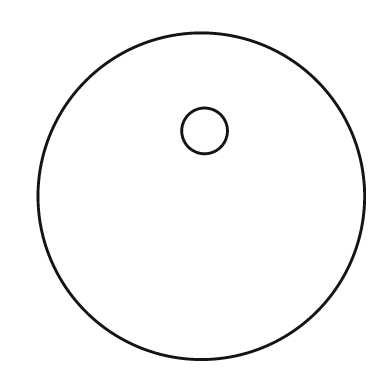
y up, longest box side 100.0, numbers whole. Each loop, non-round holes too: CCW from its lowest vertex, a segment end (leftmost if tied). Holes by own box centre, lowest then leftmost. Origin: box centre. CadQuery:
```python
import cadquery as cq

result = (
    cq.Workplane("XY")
    .moveTo(0.0, 0.0)
    .circle(50.0)
    .moveTo(1.0, 20.0)
    .circle(7.0)
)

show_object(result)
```